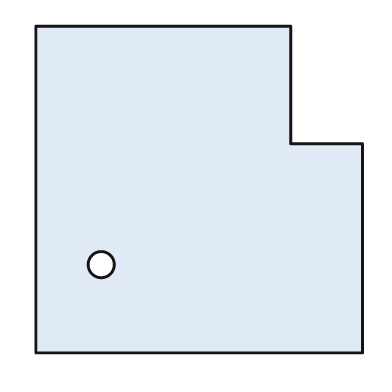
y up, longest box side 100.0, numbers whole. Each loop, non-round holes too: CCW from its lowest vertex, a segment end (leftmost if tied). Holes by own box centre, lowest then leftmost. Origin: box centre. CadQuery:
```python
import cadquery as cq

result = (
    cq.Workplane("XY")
    .moveTo(-50.0, -50.0)
    .lineTo(50.0, -50.0)
    .lineTo(50.0, 14.0)
    .lineTo(28.0, 14.0)
    .lineTo(28.0, 50.0)
    .lineTo(-50.0, 50.0)
    .close()
    .moveTo(-30.0, -23.0)
    .circle(4.0)
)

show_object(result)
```